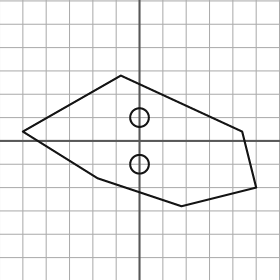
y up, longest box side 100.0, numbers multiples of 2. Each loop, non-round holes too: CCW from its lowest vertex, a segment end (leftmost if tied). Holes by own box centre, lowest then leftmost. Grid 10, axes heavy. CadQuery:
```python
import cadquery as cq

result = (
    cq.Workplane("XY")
    .moveTo(18.0, -28.0)
    .lineTo(50.0, -20.0)
    .lineTo(44.0, 4.0)
    .lineTo(-8.0, 28.0)
    .lineTo(-50.0, 4.0)
    .lineTo(-18.0, -16.0)
    .close()
    .moveTo(0.0, -10.0)
    .circle(4.0)
    .moveTo(0.0, 10.0)
    .circle(4.0)
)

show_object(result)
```